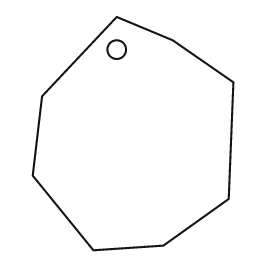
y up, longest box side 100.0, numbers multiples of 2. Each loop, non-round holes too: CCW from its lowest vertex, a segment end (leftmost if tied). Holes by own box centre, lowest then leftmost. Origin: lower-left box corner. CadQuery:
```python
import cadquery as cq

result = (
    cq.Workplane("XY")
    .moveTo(26.0, 0.0)
    .lineTo(56.0, 2.0)
    .lineTo(84.0, 22.0)
    .lineTo(86.0, 72.0)
    .lineTo(60.0, 90.0)
    .lineTo(36.0, 100.0)
    .lineTo(4.0, 66.0)
    .lineTo(0.0, 32.0)
    .close()
    .moveTo(36.0, 86.0)
    .circle(4.0)
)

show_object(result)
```